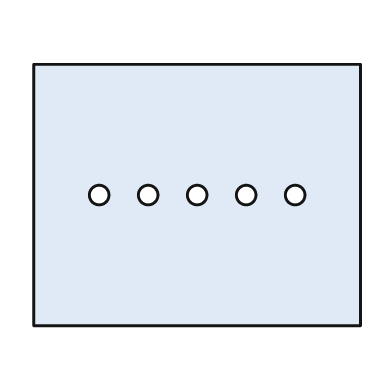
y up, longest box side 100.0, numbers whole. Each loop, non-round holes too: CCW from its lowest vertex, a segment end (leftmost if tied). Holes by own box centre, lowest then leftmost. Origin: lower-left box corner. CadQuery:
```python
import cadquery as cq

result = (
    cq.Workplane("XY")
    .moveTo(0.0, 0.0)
    .lineTo(100.0, 0.0)
    .lineTo(100.0, 80.0)
    .lineTo(0.0, 80.0)
    .close()
    .moveTo(20.0, 40.0)
    .circle(3.0)
    .moveTo(35.0, 40.0)
    .circle(3.0)
    .moveTo(50.0, 40.0)
    .circle(3.0)
    .moveTo(65.0, 40.0)
    .circle(3.0)
    .moveTo(80.0, 40.0)
    .circle(3.0)
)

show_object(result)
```